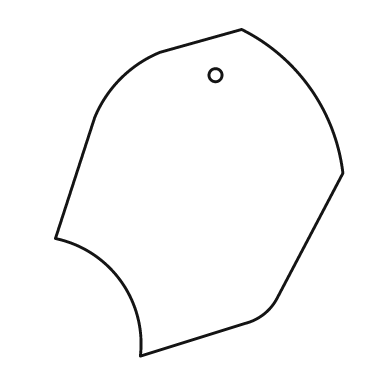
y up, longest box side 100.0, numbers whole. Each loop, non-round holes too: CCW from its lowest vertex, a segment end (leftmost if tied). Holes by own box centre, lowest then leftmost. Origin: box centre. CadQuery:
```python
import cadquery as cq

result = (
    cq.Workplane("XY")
    .moveTo(-18.0, -50.0)
    .lineTo(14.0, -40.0)
    .threePointArc((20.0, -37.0), (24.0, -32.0))
    .lineTo(44.0, 6.0)
    .threePointArc((34.0, 32.0), (13.0, 50.0))
    .lineTo(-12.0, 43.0)
    .threePointArc((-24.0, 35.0), (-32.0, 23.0))
    .lineTo(-44.0, -14.0)
    .threePointArc((-24.0, -27.0), (-18.0, -50.0))
    .close()
    .moveTo(5.0, 36.0)
    .circle(2.0)
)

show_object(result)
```